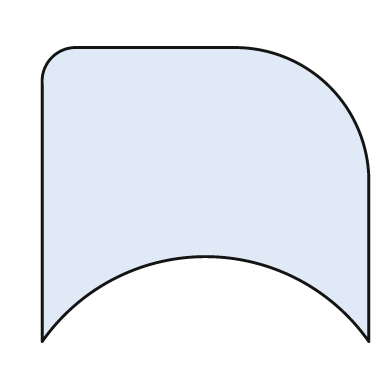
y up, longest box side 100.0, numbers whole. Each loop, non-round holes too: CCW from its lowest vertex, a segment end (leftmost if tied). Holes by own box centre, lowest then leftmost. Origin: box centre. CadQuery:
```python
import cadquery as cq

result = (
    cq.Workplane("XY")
    .moveTo(-50.0, -45.0)
    .threePointArc((0.0, -19.0), (50.0, -45.0))
    .lineTo(50.0, 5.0)
    .threePointArc((38.0, 33.0), (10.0, 45.0))
    .lineTo(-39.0, 45.0)
    .threePointArc((-47.0, 42.0), (-50.0, 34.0))
    .close()
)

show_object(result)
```